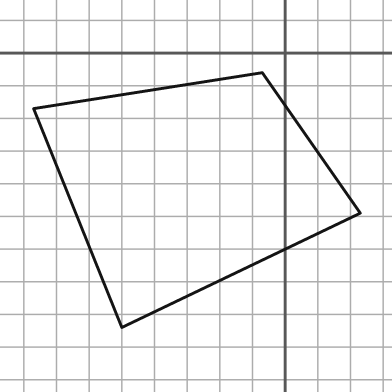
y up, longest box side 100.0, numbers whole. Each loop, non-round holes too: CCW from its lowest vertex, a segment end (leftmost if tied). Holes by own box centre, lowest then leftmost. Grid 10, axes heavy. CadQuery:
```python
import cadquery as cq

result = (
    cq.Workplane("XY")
    .moveTo(-50.0, -84.0)
    .lineTo(23.0, -49.0)
    .lineTo(-7.0, -6.0)
    .lineTo(-77.0, -17.0)
    .close()
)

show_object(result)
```